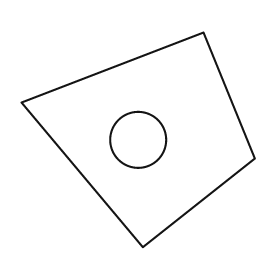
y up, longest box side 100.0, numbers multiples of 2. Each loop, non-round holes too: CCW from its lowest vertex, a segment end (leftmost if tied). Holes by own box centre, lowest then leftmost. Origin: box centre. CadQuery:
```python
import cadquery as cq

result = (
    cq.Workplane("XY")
    .moveTo(2.0, -46.0)
    .lineTo(50.0, -8.0)
    .lineTo(28.0, 46.0)
    .lineTo(-50.0, 16.0)
    .close()
    .moveTo(0.0, 0.0)
    .circle(12.0)
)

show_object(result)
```